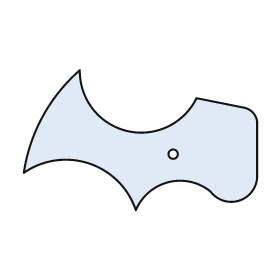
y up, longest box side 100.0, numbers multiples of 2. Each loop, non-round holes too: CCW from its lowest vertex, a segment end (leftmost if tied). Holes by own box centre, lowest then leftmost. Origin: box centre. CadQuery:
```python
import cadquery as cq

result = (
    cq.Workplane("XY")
    .moveTo(-2.0, -30.0)
    .threePointArc((12.0, -18.0), (30.0, -22.0))
    .threePointArc((42.0, -26.0), (50.0, -16.0))
    .lineTo(50.0, 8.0)
    .threePointArc((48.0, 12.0), (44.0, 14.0))
    .lineTo(24.0, 18.0)
    .threePointArc((-6.0, 4.0), (-26.0, 30.0))
    .threePointArc((-42.0, 10.0), (-50.0, -14.0))
    .threePointArc((-22.0, -10.0), (-2.0, -30.0))
    .close()
    .moveTo(14.0, -6.0)
    .circle(2.0)
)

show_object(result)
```